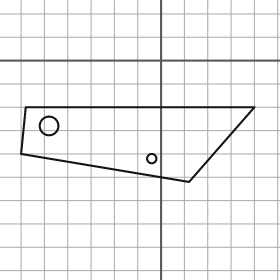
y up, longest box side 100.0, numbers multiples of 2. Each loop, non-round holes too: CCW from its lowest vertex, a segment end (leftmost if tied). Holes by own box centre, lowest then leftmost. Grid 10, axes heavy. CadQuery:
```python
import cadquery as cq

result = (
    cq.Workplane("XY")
    .moveTo(12.0, -52.0)
    .lineTo(40.0, -20.0)
    .lineTo(-58.0, -20.0)
    .lineTo(-60.0, -40.0)
    .close()
    .moveTo(-4.0, -42.0)
    .circle(2.0)
    .moveTo(-48.0, -28.0)
    .circle(4.0)
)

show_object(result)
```